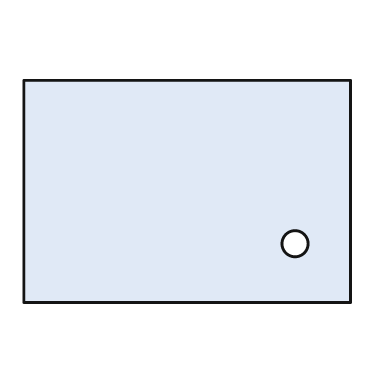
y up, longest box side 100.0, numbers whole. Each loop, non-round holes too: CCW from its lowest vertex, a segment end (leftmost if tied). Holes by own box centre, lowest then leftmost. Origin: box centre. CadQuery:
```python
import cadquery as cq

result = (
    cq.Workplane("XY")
    .moveTo(-50.0, -34.0)
    .lineTo(50.0, -34.0)
    .lineTo(50.0, 34.0)
    .lineTo(-50.0, 34.0)
    .close()
    .moveTo(33.0, -16.0)
    .circle(4.0)
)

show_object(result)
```